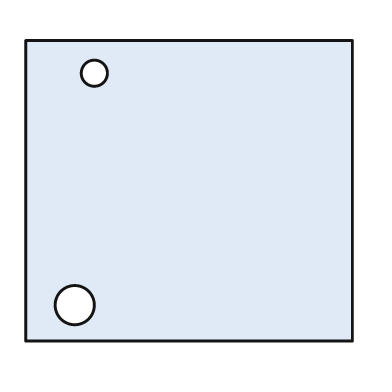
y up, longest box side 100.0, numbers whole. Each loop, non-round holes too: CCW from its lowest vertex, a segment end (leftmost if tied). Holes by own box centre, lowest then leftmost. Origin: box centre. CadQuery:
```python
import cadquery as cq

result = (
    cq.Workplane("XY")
    .moveTo(-50.0, -46.0)
    .lineTo(50.0, -46.0)
    .lineTo(50.0, 46.0)
    .lineTo(-50.0, 46.0)
    .close()
    .moveTo(-35.0, -35.0)
    .circle(6.0)
    .moveTo(-29.0, 36.0)
    .circle(4.0)
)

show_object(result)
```